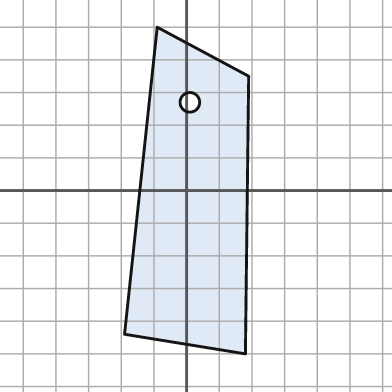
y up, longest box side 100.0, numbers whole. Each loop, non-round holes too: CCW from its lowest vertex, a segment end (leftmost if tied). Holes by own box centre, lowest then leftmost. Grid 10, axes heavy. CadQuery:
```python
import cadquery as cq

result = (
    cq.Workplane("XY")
    .moveTo(18.0, -50.0)
    .lineTo(19.0, 35.0)
    .lineTo(-9.0, 50.0)
    .lineTo(-19.0, -44.0)
    .close()
    .moveTo(1.0, 27.0)
    .circle(3.0)
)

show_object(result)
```